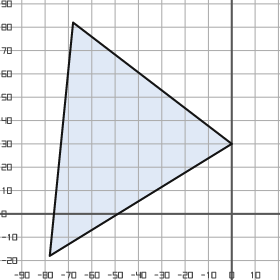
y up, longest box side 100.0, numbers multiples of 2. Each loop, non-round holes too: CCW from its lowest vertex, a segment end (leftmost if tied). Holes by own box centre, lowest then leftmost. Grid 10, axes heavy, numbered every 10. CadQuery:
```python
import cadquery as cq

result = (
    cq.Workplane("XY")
    .moveTo(-78.0, -18.0)
    .lineTo(0.0, 30.0)
    .lineTo(-68.0, 82.0)
    .close()
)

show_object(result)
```